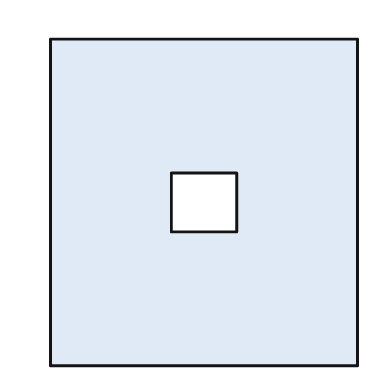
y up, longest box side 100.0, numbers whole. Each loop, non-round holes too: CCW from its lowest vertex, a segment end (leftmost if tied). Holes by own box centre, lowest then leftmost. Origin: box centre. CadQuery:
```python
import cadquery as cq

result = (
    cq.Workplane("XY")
    .moveTo(-47.0, -50.0)
    .lineTo(47.0, -50.0)
    .lineTo(47.0, 50.0)
    .lineTo(-47.0, 50.0)
    .close()
    .moveTo(-10.0, -9.0)
    .lineTo(10.0, -9.0)
    .lineTo(10.0, 9.0)
    .lineTo(-10.0, 9.0)
    .close()
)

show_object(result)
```